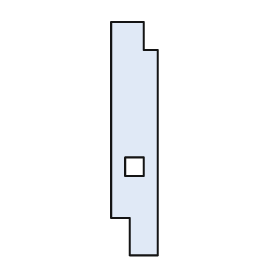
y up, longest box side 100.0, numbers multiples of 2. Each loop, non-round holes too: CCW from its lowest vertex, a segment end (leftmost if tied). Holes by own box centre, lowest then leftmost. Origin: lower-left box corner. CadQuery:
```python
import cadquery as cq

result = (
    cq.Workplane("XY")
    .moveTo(8.0, 0.0)
    .lineTo(20.0, 0.0)
    .lineTo(20.0, 88.0)
    .lineTo(14.0, 88.0)
    .lineTo(14.0, 100.0)
    .lineTo(0.0, 100.0)
    .lineTo(0.0, 16.0)
    .lineTo(8.0, 16.0)
    .close()
    .moveTo(6.0, 34.0)
    .lineTo(14.0, 34.0)
    .lineTo(14.0, 42.0)
    .lineTo(6.0, 42.0)
    .close()
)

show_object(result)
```